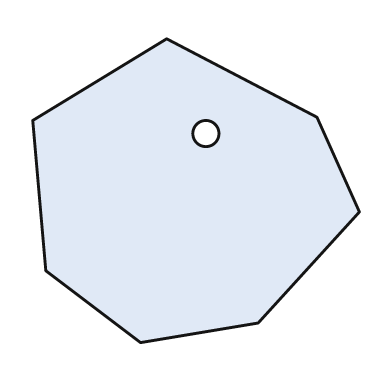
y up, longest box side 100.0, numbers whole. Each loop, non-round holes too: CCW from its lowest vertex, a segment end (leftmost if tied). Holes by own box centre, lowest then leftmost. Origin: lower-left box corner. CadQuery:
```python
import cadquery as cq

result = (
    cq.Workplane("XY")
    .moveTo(33.0, 0.0)
    .lineTo(69.0, 6.0)
    .lineTo(100.0, 40.0)
    .lineTo(87.0, 69.0)
    .lineTo(41.0, 93.0)
    .lineTo(0.0, 68.0)
    .lineTo(4.0, 22.0)
    .close()
    .moveTo(53.0, 64.0)
    .circle(4.0)
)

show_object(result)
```